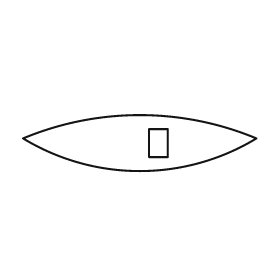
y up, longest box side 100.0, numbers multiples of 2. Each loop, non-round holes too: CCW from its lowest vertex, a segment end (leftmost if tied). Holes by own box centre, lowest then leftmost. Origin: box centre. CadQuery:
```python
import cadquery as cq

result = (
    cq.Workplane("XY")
    .moveTo(-50.0, 2.0)
    .threePointArc((0.0, -12.0), (50.0, 2.0))
    .threePointArc((0.0, 12.0), (-50.0, 2.0))
    .close()
    .moveTo(4.0, -6.0)
    .lineTo(12.0, -6.0)
    .lineTo(12.0, 6.0)
    .lineTo(4.0, 6.0)
    .close()
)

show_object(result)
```